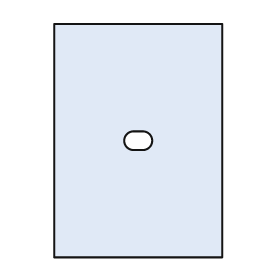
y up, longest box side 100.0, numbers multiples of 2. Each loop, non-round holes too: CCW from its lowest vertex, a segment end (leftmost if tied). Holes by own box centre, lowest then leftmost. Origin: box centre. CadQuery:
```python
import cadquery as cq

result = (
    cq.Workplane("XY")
    .moveTo(-36.0, -50.0)
    .lineTo(36.0, -50.0)
    .lineTo(36.0, 50.0)
    .lineTo(-36.0, 50.0)
    .close()
    .moveTo(-2.0, -4.0)
    .lineTo(2.0, -4.0)
    .threePointArc((6.0, 0.0), (2.0, 4.0))
    .lineTo(-2.0, 4.0)
    .threePointArc((-6.0, 0.0), (-2.0, -4.0))
    .close()
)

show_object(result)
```